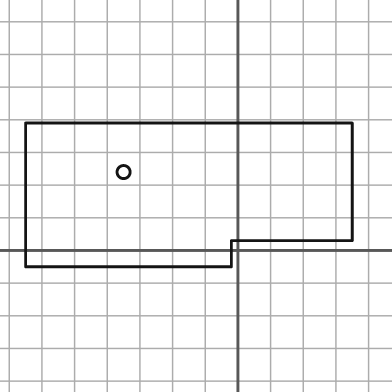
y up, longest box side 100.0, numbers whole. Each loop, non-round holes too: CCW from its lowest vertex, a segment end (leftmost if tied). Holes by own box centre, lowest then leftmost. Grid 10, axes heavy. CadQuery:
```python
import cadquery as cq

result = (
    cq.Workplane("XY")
    .moveTo(-65.0, -5.0)
    .lineTo(-2.0, -5.0)
    .lineTo(-2.0, 3.0)
    .lineTo(35.0, 3.0)
    .lineTo(35.0, 39.0)
    .lineTo(-65.0, 39.0)
    .close()
    .moveTo(-35.0, 24.0)
    .circle(2.0)
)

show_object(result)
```